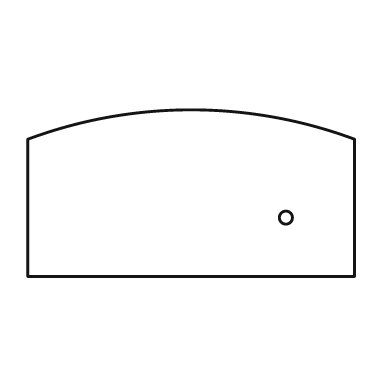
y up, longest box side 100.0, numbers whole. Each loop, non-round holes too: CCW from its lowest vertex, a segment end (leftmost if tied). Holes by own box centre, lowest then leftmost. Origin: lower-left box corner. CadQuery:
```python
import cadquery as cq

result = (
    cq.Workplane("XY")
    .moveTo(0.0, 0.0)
    .lineTo(100.0, 0.0)
    .lineTo(100.0, 42.0)
    .threePointArc((50.0, 51.0), (0.0, 42.0))
    .close()
    .moveTo(79.0, 18.0)
    .circle(2.0)
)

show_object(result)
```